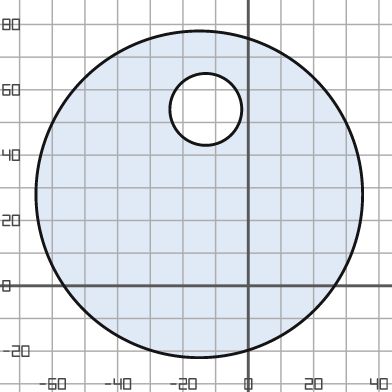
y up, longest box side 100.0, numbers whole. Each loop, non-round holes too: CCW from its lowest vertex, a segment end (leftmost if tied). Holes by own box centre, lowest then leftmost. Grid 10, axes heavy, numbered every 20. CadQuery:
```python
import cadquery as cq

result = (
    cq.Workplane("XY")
    .moveTo(-15.0, 28.0)
    .circle(50.0)
    .moveTo(-13.0, 54.0)
    .circle(11.0)
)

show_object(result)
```